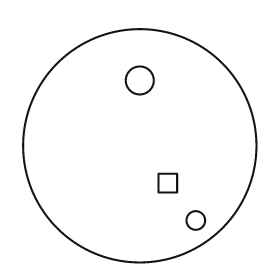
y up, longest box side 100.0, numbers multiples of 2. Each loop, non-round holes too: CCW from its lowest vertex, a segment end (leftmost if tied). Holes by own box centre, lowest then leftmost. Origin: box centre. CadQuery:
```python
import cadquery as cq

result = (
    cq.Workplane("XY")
    .moveTo(0.0, 0.0)
    .circle(50.0)
    .moveTo(24.0, -32.0)
    .circle(4.0)
    .moveTo(8.0, -20.0)
    .lineTo(16.0, -20.0)
    .lineTo(16.0, -12.0)
    .lineTo(8.0, -12.0)
    .close()
    .moveTo(0.0, 28.0)
    .circle(6.0)
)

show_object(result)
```